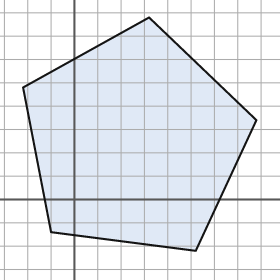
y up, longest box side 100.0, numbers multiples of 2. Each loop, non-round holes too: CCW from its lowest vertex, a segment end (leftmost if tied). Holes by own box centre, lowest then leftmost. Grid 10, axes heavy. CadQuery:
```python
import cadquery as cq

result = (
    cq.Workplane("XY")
    .moveTo(52.0, -22.0)
    .lineTo(78.0, 34.0)
    .lineTo(32.0, 78.0)
    .lineTo(-22.0, 48.0)
    .lineTo(-10.0, -14.0)
    .close()
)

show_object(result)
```